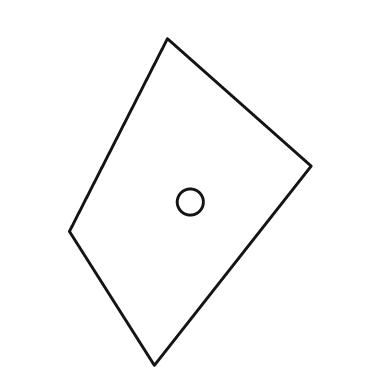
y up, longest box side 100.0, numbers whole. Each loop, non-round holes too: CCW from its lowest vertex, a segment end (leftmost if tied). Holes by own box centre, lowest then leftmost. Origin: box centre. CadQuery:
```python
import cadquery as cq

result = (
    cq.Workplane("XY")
    .moveTo(-11.0, -50.0)
    .lineTo(37.0, 11.0)
    .lineTo(-7.0, 50.0)
    .lineTo(-37.0, -9.0)
    .close()
    .moveTo(0.0, 0.0)
    .circle(4.0)
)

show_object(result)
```